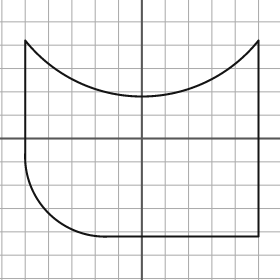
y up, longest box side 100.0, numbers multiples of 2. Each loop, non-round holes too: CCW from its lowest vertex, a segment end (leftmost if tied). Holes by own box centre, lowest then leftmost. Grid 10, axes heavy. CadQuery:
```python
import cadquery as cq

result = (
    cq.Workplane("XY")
    .moveTo(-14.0, -42.0)
    .lineTo(50.0, -42.0)
    .lineTo(50.0, 42.0)
    .threePointArc((0.0, 18.0), (-50.0, 42.0))
    .lineTo(-50.0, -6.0)
    .threePointArc((-40.0, -32.0), (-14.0, -42.0))
    .close()
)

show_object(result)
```